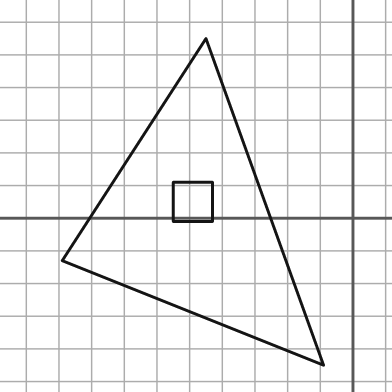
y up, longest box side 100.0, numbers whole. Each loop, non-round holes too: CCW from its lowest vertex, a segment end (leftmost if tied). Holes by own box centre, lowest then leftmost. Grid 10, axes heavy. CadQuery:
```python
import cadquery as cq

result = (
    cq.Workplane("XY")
    .moveTo(-9.0, -45.0)
    .lineTo(-45.0, 55.0)
    .lineTo(-89.0, -13.0)
    .close()
    .moveTo(-55.0, -1.0)
    .lineTo(-43.0, -1.0)
    .lineTo(-43.0, 11.0)
    .lineTo(-55.0, 11.0)
    .close()
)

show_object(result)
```